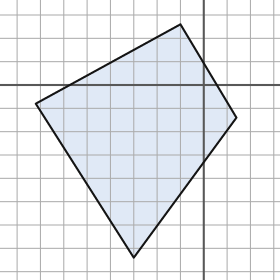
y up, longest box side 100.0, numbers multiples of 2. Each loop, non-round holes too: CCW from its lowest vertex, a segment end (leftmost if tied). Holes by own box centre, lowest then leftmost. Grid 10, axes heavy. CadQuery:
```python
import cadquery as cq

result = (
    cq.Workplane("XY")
    .moveTo(-30.0, -74.0)
    .lineTo(14.0, -14.0)
    .lineTo(-10.0, 26.0)
    .lineTo(-72.0, -8.0)
    .close()
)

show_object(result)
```